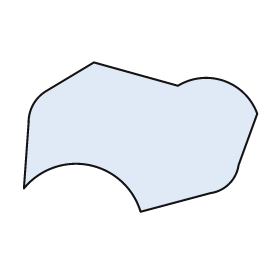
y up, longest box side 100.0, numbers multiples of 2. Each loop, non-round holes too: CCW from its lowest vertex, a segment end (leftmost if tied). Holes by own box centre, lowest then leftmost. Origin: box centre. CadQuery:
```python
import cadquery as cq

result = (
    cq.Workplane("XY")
    .moveTo(0.0, -32.0)
    .lineTo(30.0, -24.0)
    .threePointArc((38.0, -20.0), (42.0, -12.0))
    .lineTo(50.0, 10.0)
    .threePointArc((36.0, 24.0), (16.0, 22.0))
    .lineTo(-20.0, 32.0)
    .lineTo(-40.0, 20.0)
    .threePointArc((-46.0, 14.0), (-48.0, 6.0))
    .lineTo(-50.0, -22.0)
    .threePointArc((-22.0, -12.0), (0.0, -32.0))
    .close()
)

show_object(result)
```